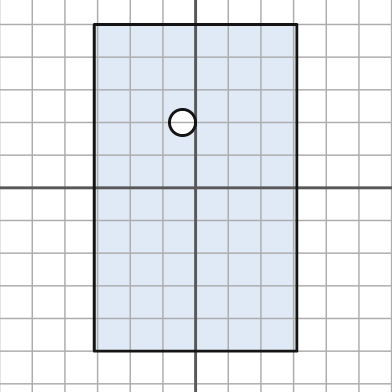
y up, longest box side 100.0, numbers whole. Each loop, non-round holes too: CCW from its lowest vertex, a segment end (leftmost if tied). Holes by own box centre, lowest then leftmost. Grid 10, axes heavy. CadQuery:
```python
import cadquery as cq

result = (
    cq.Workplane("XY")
    .moveTo(-31.0, -50.0)
    .lineTo(31.0, -50.0)
    .lineTo(31.0, 50.0)
    .lineTo(-31.0, 50.0)
    .close()
    .moveTo(-4.0, 20.0)
    .circle(4.0)
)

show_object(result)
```